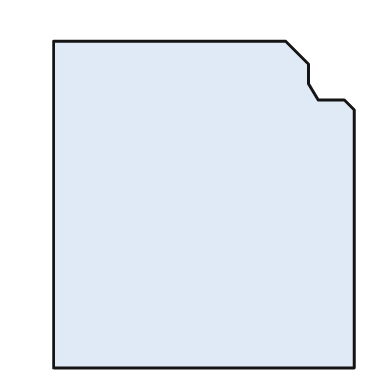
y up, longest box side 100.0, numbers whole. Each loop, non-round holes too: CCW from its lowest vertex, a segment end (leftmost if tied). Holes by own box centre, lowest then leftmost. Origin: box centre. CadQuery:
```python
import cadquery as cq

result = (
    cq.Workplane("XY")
    .moveTo(-46.0, -50.0)
    .lineTo(46.0, -50.0)
    .lineTo(46.0, 29.0)
    .lineTo(43.0, 32.0)
    .lineTo(35.0, 32.0)
    .lineTo(32.0, 37.0)
    .lineTo(32.0, 43.0)
    .lineTo(25.0, 50.0)
    .lineTo(-46.0, 50.0)
    .close()
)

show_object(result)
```